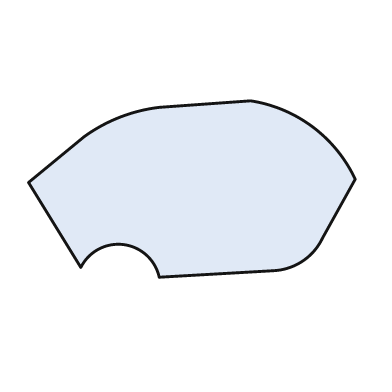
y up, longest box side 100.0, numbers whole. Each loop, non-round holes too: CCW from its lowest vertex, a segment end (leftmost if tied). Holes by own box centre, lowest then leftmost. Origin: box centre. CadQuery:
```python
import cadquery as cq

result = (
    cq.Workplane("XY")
    .moveTo(-10.0, -27.0)
    .lineTo(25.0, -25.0)
    .threePointArc((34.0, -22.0), (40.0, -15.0))
    .lineTo(50.0, 3.0)
    .threePointArc((37.0, 19.0), (18.0, 27.0))
    .lineTo(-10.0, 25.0)
    .threePointArc((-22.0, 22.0), (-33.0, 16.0))
    .lineTo(-50.0, 2.0)
    .lineTo(-34.0, -24.0)
    .threePointArc((-21.0, -17.0), (-10.0, -27.0))
    .close()
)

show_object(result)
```